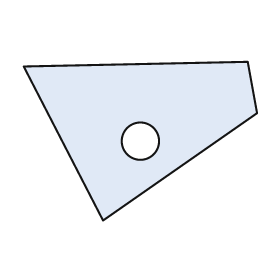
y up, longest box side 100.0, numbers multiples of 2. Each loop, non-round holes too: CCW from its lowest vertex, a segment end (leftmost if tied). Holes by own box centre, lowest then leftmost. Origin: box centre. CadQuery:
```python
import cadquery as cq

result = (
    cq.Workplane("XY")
    .moveTo(-16.0, -34.0)
    .lineTo(50.0, 12.0)
    .lineTo(46.0, 34.0)
    .lineTo(-50.0, 32.0)
    .close()
    .moveTo(0.0, 0.0)
    .circle(8.0)
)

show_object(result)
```